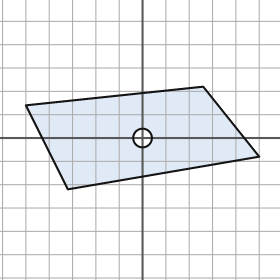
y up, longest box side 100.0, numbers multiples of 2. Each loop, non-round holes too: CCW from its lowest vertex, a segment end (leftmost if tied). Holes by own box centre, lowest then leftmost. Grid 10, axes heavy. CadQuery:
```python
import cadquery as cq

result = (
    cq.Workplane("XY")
    .moveTo(-32.0, -22.0)
    .lineTo(50.0, -8.0)
    .lineTo(26.0, 22.0)
    .lineTo(-50.0, 14.0)
    .close()
    .moveTo(0.0, 0.0)
    .circle(4.0)
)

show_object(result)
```